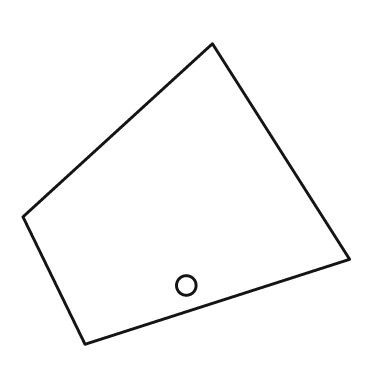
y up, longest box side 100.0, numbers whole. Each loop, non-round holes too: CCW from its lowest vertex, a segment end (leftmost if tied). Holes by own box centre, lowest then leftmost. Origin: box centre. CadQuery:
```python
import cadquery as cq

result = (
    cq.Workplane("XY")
    .moveTo(-31.0, -46.0)
    .lineTo(50.0, -20.0)
    .lineTo(8.0, 46.0)
    .lineTo(-50.0, -7.0)
    .close()
    .moveTo(0.0, -28.0)
    .circle(3.0)
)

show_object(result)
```